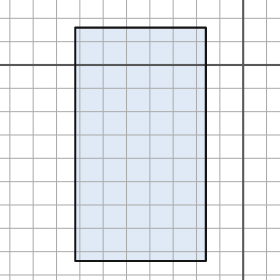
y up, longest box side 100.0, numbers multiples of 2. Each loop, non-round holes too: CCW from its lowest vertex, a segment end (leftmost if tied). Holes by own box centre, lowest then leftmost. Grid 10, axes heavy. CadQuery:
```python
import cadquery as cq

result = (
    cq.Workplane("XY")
    .moveTo(-72.0, -84.0)
    .lineTo(-16.0, -84.0)
    .lineTo(-16.0, 16.0)
    .lineTo(-72.0, 16.0)
    .close()
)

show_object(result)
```